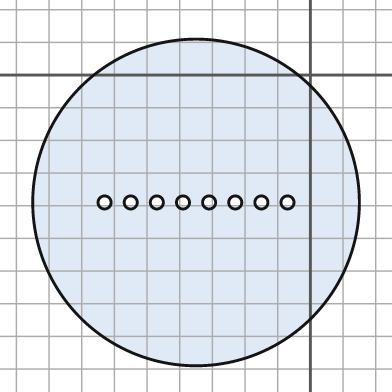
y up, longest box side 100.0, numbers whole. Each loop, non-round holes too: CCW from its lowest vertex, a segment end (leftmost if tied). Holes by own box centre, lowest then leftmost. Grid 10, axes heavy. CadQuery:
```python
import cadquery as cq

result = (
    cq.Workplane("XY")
    .moveTo(-35.0, -39.0)
    .circle(50.0)
    .moveTo(-63.0, -39.0)
    .circle(2.0)
    .moveTo(-55.0, -39.0)
    .circle(2.0)
    .moveTo(-47.0, -39.0)
    .circle(2.0)
    .moveTo(-39.0, -39.0)
    .circle(2.0)
    .moveTo(-31.0, -39.0)
    .circle(2.0)
    .moveTo(-23.0, -39.0)
    .circle(2.0)
    .moveTo(-15.0, -39.0)
    .circle(2.0)
    .moveTo(-7.0, -39.0)
    .circle(2.0)
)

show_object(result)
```